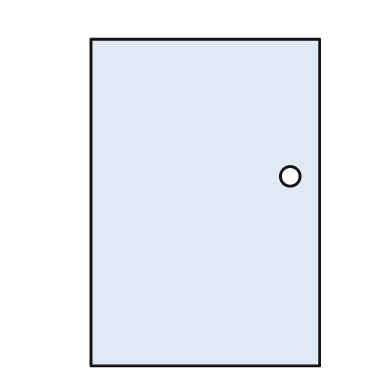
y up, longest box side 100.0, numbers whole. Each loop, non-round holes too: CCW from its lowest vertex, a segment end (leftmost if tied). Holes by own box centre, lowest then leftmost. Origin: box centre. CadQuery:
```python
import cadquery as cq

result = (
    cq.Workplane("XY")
    .moveTo(-35.0, -50.0)
    .lineTo(35.0, -50.0)
    .lineTo(35.0, 50.0)
    .lineTo(-35.0, 50.0)
    .close()
    .moveTo(26.0, 8.0)
    .circle(3.0)
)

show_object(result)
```